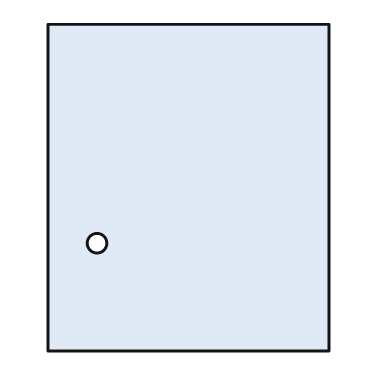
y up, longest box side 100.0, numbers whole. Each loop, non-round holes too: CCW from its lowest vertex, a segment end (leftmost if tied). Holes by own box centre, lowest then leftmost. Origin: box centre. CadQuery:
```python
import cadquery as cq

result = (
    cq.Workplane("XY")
    .moveTo(-43.0, -50.0)
    .lineTo(43.0, -50.0)
    .lineTo(43.0, 50.0)
    .lineTo(-43.0, 50.0)
    .close()
    .moveTo(-28.0, -17.0)
    .circle(3.0)
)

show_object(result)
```